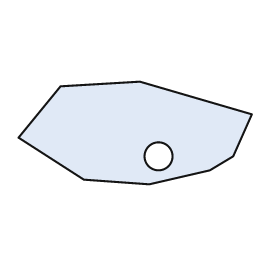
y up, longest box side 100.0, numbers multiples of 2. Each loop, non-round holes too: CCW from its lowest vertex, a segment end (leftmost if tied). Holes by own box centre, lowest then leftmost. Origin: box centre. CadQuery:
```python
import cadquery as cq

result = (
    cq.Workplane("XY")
    .moveTo(6.0, -22.0)
    .lineTo(32.0, -16.0)
    .lineTo(42.0, -10.0)
    .lineTo(50.0, 8.0)
    .lineTo(2.0, 22.0)
    .lineTo(-32.0, 20.0)
    .lineTo(-50.0, -2.0)
    .lineTo(-22.0, -20.0)
    .close()
    .moveTo(10.0, -10.0)
    .circle(6.0)
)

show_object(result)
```